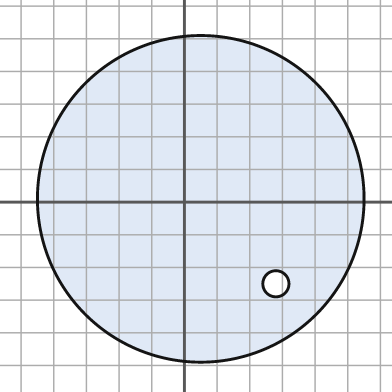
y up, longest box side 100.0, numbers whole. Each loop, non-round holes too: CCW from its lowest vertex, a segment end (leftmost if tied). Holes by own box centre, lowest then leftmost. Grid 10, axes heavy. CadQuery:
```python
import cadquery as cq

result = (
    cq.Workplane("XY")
    .moveTo(5.0, 1.0)
    .circle(50.0)
    .moveTo(28.0, -25.0)
    .circle(4.0)
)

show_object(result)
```